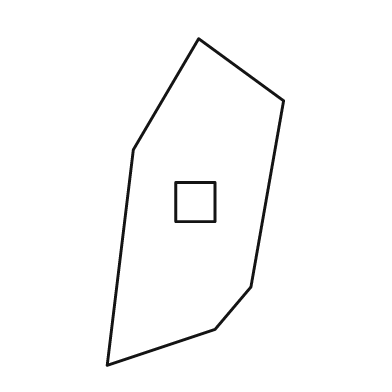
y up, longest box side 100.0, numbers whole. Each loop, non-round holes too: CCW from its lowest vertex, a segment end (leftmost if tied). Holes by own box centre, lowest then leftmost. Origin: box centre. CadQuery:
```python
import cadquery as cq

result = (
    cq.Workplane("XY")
    .moveTo(-27.0, -50.0)
    .lineTo(6.0, -39.0)
    .lineTo(17.0, -26.0)
    .lineTo(27.0, 31.0)
    .lineTo(1.0, 50.0)
    .lineTo(-19.0, 16.0)
    .close()
    .moveTo(-6.0, -6.0)
    .lineTo(6.0, -6.0)
    .lineTo(6.0, 6.0)
    .lineTo(-6.0, 6.0)
    .close()
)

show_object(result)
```